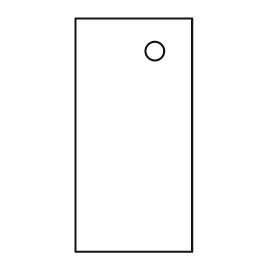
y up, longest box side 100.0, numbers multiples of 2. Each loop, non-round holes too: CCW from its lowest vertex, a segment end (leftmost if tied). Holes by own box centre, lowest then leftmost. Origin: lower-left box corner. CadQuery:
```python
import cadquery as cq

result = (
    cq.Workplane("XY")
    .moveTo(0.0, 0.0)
    .lineTo(50.0, 0.0)
    .lineTo(50.0, 100.0)
    .lineTo(0.0, 100.0)
    .close()
    .moveTo(34.0, 86.0)
    .circle(4.0)
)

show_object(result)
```